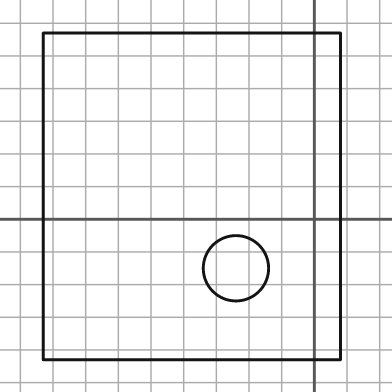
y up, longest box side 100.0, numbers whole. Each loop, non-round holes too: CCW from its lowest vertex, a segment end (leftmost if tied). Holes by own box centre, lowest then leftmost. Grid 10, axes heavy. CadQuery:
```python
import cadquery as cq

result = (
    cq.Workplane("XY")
    .moveTo(-83.0, -43.0)
    .lineTo(8.0, -43.0)
    .lineTo(8.0, 57.0)
    .lineTo(-83.0, 57.0)
    .close()
    .moveTo(-24.0, -15.0)
    .circle(10.0)
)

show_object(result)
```